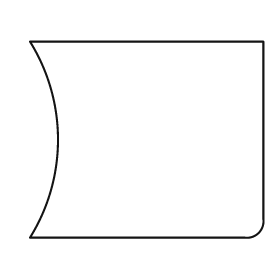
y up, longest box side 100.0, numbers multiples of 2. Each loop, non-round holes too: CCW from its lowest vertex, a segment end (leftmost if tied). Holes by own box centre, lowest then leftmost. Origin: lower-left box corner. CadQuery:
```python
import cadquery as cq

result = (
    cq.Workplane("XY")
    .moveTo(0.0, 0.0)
    .lineTo(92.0, 0.0)
    .threePointArc((98.0, 2.0), (100.0, 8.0))
    .lineTo(100.0, 84.0)
    .lineTo(0.0, 84.0)
    .threePointArc((12.0, 42.0), (0.0, 0.0))
    .close()
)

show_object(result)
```